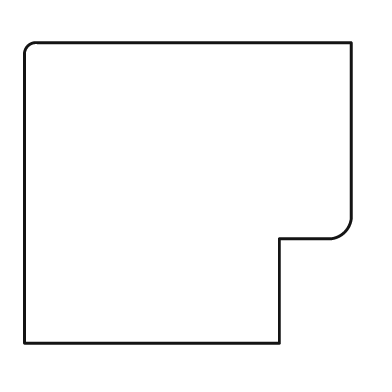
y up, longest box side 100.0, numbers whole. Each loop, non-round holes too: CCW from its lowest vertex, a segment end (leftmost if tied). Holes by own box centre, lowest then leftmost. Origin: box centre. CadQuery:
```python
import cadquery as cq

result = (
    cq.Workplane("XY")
    .moveTo(-50.0, -46.0)
    .lineTo(28.0, -46.0)
    .lineTo(28.0, -14.0)
    .lineTo(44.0, -14.0)
    .threePointArc((48.0, -12.0), (50.0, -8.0))
    .lineTo(50.0, 46.0)
    .lineTo(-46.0, 46.0)
    .threePointArc((-49.0, 45.0), (-50.0, 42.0))
    .close()
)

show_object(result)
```